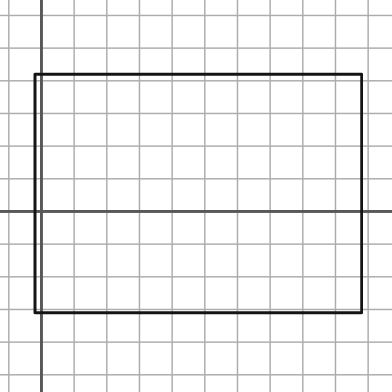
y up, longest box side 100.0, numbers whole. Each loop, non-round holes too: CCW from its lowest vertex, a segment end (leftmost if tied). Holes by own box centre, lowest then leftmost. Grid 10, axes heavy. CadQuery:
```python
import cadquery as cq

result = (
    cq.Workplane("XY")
    .moveTo(-2.0, -31.0)
    .lineTo(98.0, -31.0)
    .lineTo(98.0, 42.0)
    .lineTo(-2.0, 42.0)
    .close()
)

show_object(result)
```